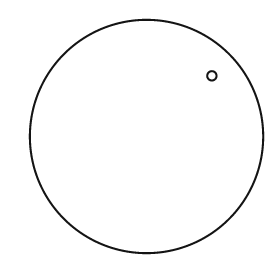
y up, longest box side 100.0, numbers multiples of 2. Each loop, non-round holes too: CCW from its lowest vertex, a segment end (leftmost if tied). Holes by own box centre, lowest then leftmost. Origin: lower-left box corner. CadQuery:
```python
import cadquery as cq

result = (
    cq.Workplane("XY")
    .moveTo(50.0, 50.0)
    .circle(50.0)
    .moveTo(78.0, 76.0)
    .circle(2.0)
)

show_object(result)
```